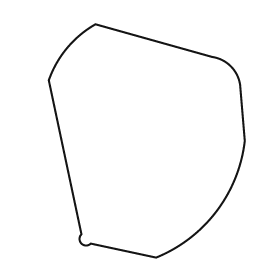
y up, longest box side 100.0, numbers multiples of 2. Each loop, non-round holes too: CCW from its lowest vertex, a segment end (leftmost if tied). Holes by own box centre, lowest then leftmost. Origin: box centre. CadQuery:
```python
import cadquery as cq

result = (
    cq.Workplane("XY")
    .moveTo(4.0, -50.0)
    .threePointArc((30.0, -30.0), (42.0, 0.0))
    .lineTo(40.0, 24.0)
    .threePointArc((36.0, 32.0), (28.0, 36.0))
    .lineTo(-22.0, 50.0)
    .threePointArc((-34.0, 40.0), (-42.0, 26.0))
    .lineTo(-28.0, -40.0)
    .threePointArc((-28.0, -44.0), (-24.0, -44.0))
    .close()
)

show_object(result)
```